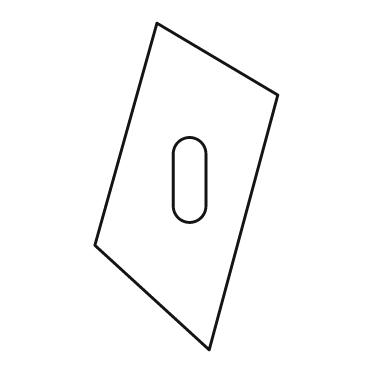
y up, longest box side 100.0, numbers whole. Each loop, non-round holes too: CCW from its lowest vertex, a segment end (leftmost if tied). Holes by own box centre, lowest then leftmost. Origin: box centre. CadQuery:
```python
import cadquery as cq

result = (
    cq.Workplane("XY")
    .moveTo(7.0, -50.0)
    .lineTo(28.0, 28.0)
    .lineTo(-9.0, 50.0)
    .lineTo(-28.0, -18.0)
    .close()
    .moveTo(-4.0, -6.0)
    .threePointArc((1.0, -11.0), (6.0, -6.0))
    .lineTo(6.0, 10.0)
    .threePointArc((1.0, 15.0), (-4.0, 10.0))
    .close()
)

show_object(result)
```